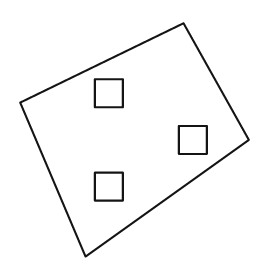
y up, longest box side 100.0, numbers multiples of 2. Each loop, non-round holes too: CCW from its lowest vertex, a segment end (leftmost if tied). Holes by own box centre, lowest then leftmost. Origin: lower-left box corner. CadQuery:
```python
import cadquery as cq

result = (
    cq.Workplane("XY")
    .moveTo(28.0, 0.0)
    .lineTo(98.0, 50.0)
    .lineTo(70.0, 100.0)
    .lineTo(0.0, 66.0)
    .close()
    .moveTo(32.0, 24.0)
    .lineTo(44.0, 24.0)
    .lineTo(44.0, 36.0)
    .lineTo(32.0, 36.0)
    .close()
    .moveTo(68.0, 44.0)
    .lineTo(80.0, 44.0)
    .lineTo(80.0, 56.0)
    .lineTo(68.0, 56.0)
    .close()
    .moveTo(32.0, 64.0)
    .lineTo(44.0, 64.0)
    .lineTo(44.0, 76.0)
    .lineTo(32.0, 76.0)
    .close()
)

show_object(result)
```